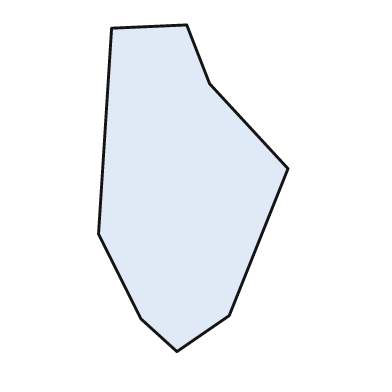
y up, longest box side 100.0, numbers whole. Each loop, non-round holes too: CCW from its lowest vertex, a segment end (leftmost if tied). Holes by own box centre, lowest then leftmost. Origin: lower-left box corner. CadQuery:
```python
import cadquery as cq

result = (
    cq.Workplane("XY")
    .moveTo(24.0, 0.0)
    .lineTo(40.0, 11.0)
    .lineTo(58.0, 56.0)
    .lineTo(34.0, 82.0)
    .lineTo(27.0, 100.0)
    .lineTo(4.0, 99.0)
    .lineTo(0.0, 36.0)
    .lineTo(13.0, 10.0)
    .close()
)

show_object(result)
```